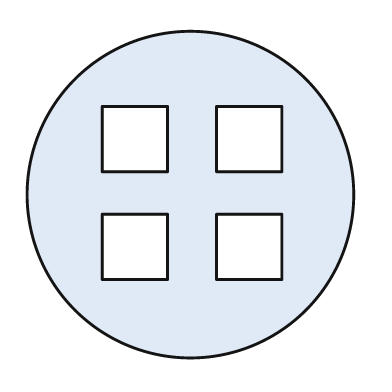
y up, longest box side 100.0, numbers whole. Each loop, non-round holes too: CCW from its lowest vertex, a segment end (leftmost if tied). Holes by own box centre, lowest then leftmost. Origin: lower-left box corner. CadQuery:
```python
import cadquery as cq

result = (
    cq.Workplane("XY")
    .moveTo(50.0, 50.0)
    .circle(50.0)
    .moveTo(23.0, 24.0)
    .lineTo(43.0, 24.0)
    .lineTo(43.0, 44.0)
    .lineTo(23.0, 44.0)
    .close()
    .moveTo(58.0, 24.0)
    .lineTo(78.0, 24.0)
    .lineTo(78.0, 44.0)
    .lineTo(58.0, 44.0)
    .close()
    .moveTo(23.0, 57.0)
    .lineTo(43.0, 57.0)
    .lineTo(43.0, 77.0)
    .lineTo(23.0, 77.0)
    .close()
    .moveTo(58.0, 57.0)
    .lineTo(78.0, 57.0)
    .lineTo(78.0, 77.0)
    .lineTo(58.0, 77.0)
    .close()
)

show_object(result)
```